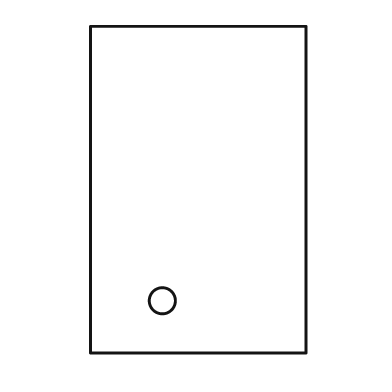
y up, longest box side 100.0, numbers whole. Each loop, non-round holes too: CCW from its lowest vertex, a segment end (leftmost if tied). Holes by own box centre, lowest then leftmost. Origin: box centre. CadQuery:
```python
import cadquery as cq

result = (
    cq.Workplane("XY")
    .moveTo(-33.0, -50.0)
    .lineTo(33.0, -50.0)
    .lineTo(33.0, 50.0)
    .lineTo(-33.0, 50.0)
    .close()
    .moveTo(-11.0, -34.0)
    .circle(4.0)
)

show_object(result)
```